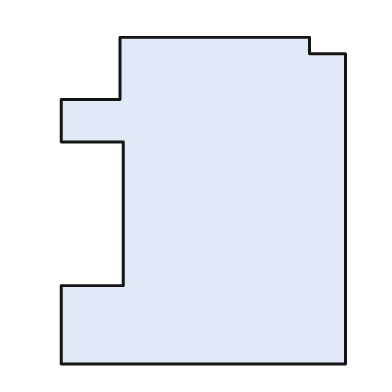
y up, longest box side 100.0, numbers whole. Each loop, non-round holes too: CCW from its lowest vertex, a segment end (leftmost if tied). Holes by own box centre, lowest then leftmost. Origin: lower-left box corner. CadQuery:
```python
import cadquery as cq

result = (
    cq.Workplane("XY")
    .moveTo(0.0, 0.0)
    .lineTo(87.0, 0.0)
    .lineTo(87.0, 95.0)
    .lineTo(76.0, 95.0)
    .lineTo(76.0, 100.0)
    .lineTo(18.0, 100.0)
    .lineTo(18.0, 81.0)
    .lineTo(0.0, 81.0)
    .lineTo(0.0, 68.0)
    .lineTo(19.0, 68.0)
    .lineTo(19.0, 24.0)
    .lineTo(0.0, 24.0)
    .close()
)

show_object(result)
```